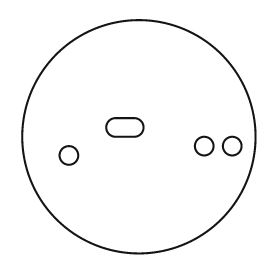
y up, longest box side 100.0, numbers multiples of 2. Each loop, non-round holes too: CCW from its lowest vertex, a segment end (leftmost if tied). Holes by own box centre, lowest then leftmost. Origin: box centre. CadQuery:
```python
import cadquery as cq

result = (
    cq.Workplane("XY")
    .moveTo(0.0, 0.0)
    .circle(50.0)
    .moveTo(-30.0, -8.0)
    .circle(4.0)
    .moveTo(28.0, -4.0)
    .circle(4.0)
    .moveTo(40.0, -4.0)
    .circle(4.0)
    .moveTo(-10.0, 0.0)
    .lineTo(-2.0, 0.0)
    .threePointArc((2.0, 4.0), (-2.0, 8.0))
    .lineTo(-10.0, 8.0)
    .threePointArc((-14.0, 4.0), (-10.0, 0.0))
    .close()
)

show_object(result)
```